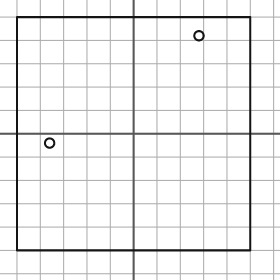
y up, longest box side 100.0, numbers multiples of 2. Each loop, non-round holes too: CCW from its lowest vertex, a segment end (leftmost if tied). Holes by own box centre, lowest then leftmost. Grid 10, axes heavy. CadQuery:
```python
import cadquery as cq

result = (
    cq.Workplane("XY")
    .moveTo(-50.0, -50.0)
    .lineTo(50.0, -50.0)
    .lineTo(50.0, 50.0)
    .lineTo(-50.0, 50.0)
    .close()
    .moveTo(-36.0, -4.0)
    .circle(2.0)
    .moveTo(28.0, 42.0)
    .circle(2.0)
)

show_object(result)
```